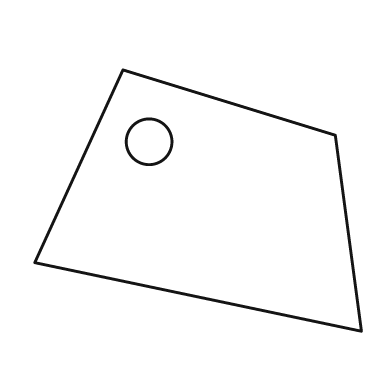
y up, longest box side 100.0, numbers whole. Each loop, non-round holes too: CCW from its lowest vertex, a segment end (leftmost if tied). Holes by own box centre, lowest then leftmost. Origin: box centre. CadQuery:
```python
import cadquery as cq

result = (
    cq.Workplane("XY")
    .moveTo(50.0, -40.0)
    .lineTo(42.0, 20.0)
    .lineTo(-23.0, 40.0)
    .lineTo(-50.0, -19.0)
    .close()
    .moveTo(-15.0, 18.0)
    .circle(7.0)
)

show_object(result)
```